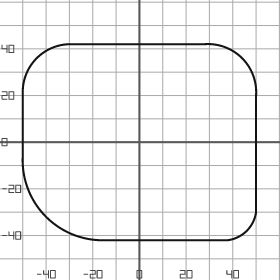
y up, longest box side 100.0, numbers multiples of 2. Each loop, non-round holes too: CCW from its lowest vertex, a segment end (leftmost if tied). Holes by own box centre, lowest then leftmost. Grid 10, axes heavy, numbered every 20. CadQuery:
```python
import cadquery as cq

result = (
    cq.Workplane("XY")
    .moveTo(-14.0, -42.0)
    .lineTo(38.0, -42.0)
    .threePointArc((46.0, -38.0), (50.0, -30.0))
    .lineTo(50.0, 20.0)
    .threePointArc((44.0, 36.0), (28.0, 42.0))
    .lineTo(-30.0, 42.0)
    .threePointArc((-44.0, 36.0), (-50.0, 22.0))
    .lineTo(-50.0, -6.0)
    .threePointArc((-40.0, -32.0), (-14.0, -42.0))
    .close()
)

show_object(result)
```